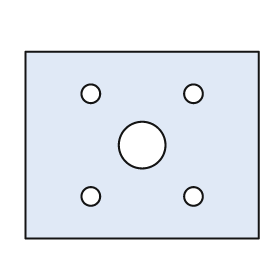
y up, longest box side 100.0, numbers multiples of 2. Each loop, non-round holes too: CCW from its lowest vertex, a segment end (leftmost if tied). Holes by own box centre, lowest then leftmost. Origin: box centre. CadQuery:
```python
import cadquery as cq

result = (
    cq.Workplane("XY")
    .moveTo(-50.0, -40.0)
    .lineTo(50.0, -40.0)
    .lineTo(50.0, 40.0)
    .lineTo(-50.0, 40.0)
    .close()
    .moveTo(-22.0, -22.0)
    .circle(4.0)
    .moveTo(22.0, -22.0)
    .circle(4.0)
    .moveTo(0.0, 0.0)
    .circle(10.0)
    .moveTo(-22.0, 22.0)
    .circle(4.0)
    .moveTo(22.0, 22.0)
    .circle(4.0)
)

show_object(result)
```